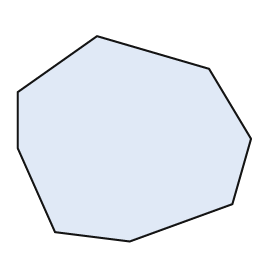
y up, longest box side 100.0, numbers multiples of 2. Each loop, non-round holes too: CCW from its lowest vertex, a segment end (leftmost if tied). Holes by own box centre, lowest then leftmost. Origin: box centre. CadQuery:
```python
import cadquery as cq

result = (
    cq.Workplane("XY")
    .moveTo(-2.0, -44.0)
    .lineTo(42.0, -28.0)
    .lineTo(50.0, 0.0)
    .lineTo(32.0, 30.0)
    .lineTo(-16.0, 44.0)
    .lineTo(-50.0, 20.0)
    .lineTo(-50.0, -4.0)
    .lineTo(-34.0, -40.0)
    .close()
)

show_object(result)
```